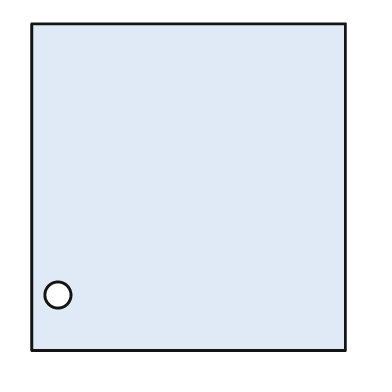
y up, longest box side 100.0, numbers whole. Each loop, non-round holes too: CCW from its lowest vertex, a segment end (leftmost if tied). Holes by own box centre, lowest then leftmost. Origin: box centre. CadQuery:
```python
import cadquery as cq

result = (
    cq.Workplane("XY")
    .moveTo(-48.0, -50.0)
    .lineTo(48.0, -50.0)
    .lineTo(48.0, 50.0)
    .lineTo(-48.0, 50.0)
    .close()
    .moveTo(-40.0, -33.0)
    .circle(4.0)
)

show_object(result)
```